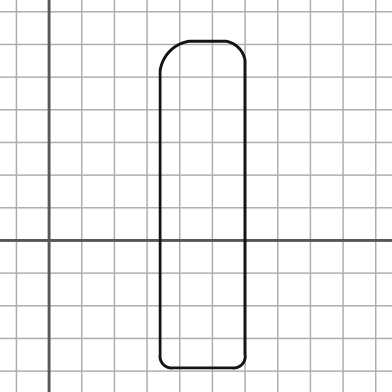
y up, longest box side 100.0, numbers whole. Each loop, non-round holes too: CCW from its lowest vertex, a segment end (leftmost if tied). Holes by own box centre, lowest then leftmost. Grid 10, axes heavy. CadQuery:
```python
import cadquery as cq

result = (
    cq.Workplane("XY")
    .moveTo(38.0, -39.0)
    .lineTo(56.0, -39.0)
    .threePointArc((59.0, -38.0), (60.0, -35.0))
    .lineTo(60.0, 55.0)
    .threePointArc((58.0, 59.0), (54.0, 61.0))
    .lineTo(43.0, 61.0)
    .threePointArc((37.0, 58.0), (34.0, 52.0))
    .lineTo(34.0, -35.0)
    .threePointArc((35.0, -38.0), (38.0, -39.0))
    .close()
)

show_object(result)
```